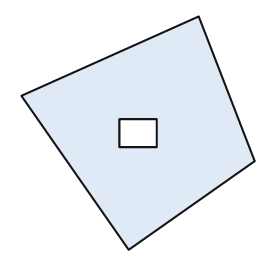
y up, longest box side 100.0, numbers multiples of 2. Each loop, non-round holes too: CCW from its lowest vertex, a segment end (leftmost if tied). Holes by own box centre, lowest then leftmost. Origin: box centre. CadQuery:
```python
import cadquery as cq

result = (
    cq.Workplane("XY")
    .moveTo(-4.0, -50.0)
    .lineTo(50.0, -12.0)
    .lineTo(26.0, 50.0)
    .lineTo(-50.0, 16.0)
    .close()
    .moveTo(-8.0, -6.0)
    .lineTo(8.0, -6.0)
    .lineTo(8.0, 6.0)
    .lineTo(-8.0, 6.0)
    .close()
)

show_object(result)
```